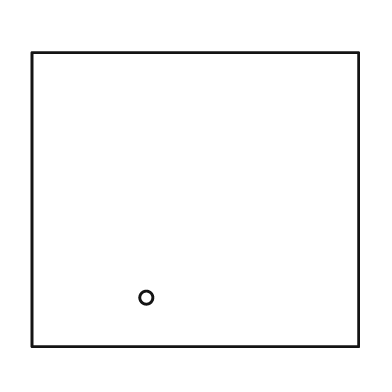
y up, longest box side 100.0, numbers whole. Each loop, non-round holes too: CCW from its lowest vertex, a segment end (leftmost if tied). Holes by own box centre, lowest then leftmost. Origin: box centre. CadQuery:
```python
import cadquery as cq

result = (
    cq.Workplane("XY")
    .moveTo(-50.0, -45.0)
    .lineTo(50.0, -45.0)
    .lineTo(50.0, 45.0)
    .lineTo(-50.0, 45.0)
    .close()
    .moveTo(-15.0, -30.0)
    .circle(2.0)
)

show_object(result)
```